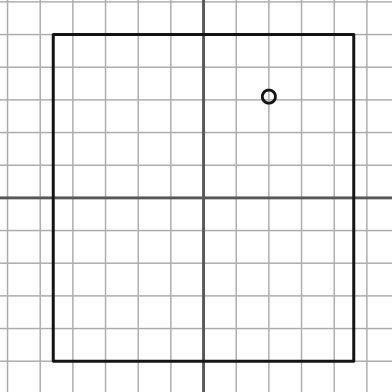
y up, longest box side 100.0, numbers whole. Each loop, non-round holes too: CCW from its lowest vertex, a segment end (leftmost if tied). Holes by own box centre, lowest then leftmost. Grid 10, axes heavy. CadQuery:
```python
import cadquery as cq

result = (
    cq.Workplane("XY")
    .moveTo(-46.0, -50.0)
    .lineTo(46.0, -50.0)
    .lineTo(46.0, 50.0)
    .lineTo(-46.0, 50.0)
    .close()
    .moveTo(20.0, 31.0)
    .circle(2.0)
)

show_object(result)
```